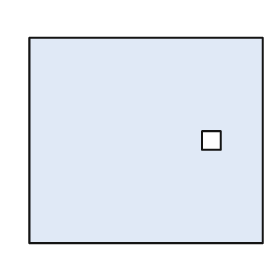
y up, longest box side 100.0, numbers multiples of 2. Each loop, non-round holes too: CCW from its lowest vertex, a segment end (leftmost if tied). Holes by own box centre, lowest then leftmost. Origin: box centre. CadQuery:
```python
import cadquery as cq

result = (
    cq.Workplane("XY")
    .moveTo(-50.0, -44.0)
    .lineTo(50.0, -44.0)
    .lineTo(50.0, 44.0)
    .lineTo(-50.0, 44.0)
    .close()
    .moveTo(24.0, -4.0)
    .lineTo(32.0, -4.0)
    .lineTo(32.0, 4.0)
    .lineTo(24.0, 4.0)
    .close()
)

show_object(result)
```